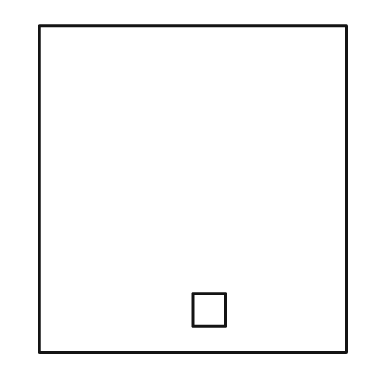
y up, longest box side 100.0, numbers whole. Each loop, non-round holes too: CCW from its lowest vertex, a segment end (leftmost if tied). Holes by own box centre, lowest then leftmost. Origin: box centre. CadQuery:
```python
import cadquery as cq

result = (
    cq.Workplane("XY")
    .moveTo(-47.0, -50.0)
    .lineTo(47.0, -50.0)
    .lineTo(47.0, 50.0)
    .lineTo(-47.0, 50.0)
    .close()
    .moveTo(0.0, -42.0)
    .lineTo(10.0, -42.0)
    .lineTo(10.0, -32.0)
    .lineTo(0.0, -32.0)
    .close()
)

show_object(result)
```